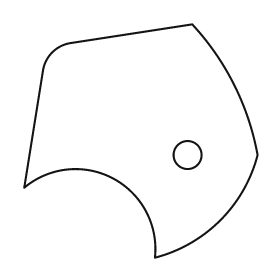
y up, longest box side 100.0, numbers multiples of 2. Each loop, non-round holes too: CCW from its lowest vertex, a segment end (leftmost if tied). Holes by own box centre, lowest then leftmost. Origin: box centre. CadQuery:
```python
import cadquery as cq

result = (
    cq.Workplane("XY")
    .moveTo(6.0, -50.0)
    .threePointArc((34.0, -34.0), (50.0, -6.0))
    .threePointArc((40.0, 24.0), (22.0, 50.0))
    .lineTo(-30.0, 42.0)
    .threePointArc((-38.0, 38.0), (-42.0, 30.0))
    .lineTo(-50.0, -20.0)
    .threePointArc((-12.0, -16.0), (6.0, -50.0))
    .close()
    .moveTo(20.0, -6.0)
    .circle(6.0)
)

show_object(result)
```